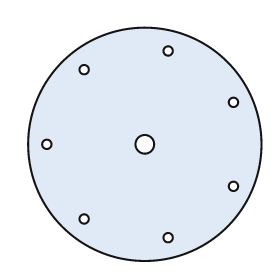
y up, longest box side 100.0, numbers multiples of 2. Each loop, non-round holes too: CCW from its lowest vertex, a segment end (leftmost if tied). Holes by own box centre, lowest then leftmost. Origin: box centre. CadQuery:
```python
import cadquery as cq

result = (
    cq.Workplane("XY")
    .moveTo(0.0, 0.0)
    .circle(50.0)
    .moveTo(10.0, -40.0)
    .circle(2.0)
    .moveTo(-26.0, -32.0)
    .circle(2.0)
    .moveTo(38.0, -18.0)
    .circle(2.0)
    .moveTo(-42.0, 0.0)
    .circle(2.0)
    .moveTo(0.0, 0.0)
    .circle(4.0)
    .moveTo(38.0, 18.0)
    .circle(2.0)
    .moveTo(-26.0, 32.0)
    .circle(2.0)
    .moveTo(10.0, 40.0)
    .circle(2.0)
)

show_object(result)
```